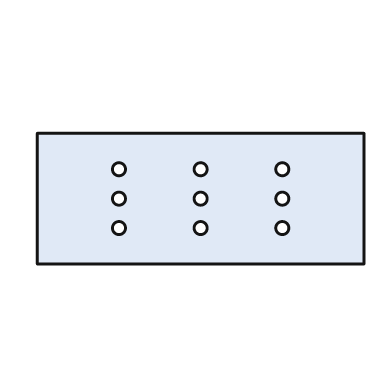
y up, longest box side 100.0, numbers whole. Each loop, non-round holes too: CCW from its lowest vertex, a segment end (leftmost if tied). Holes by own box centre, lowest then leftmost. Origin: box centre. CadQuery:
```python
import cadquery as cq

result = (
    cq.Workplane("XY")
    .moveTo(-50.0, -20.0)
    .lineTo(50.0, -20.0)
    .lineTo(50.0, 20.0)
    .lineTo(-50.0, 20.0)
    .close()
    .moveTo(-25.0, -9.0)
    .circle(2.0)
    .moveTo(0.0, -9.0)
    .circle(2.0)
    .moveTo(25.0, -9.0)
    .circle(2.0)
    .moveTo(-25.0, 0.0)
    .circle(2.0)
    .moveTo(0.0, 0.0)
    .circle(2.0)
    .moveTo(25.0, 0.0)
    .circle(2.0)
    .moveTo(-25.0, 9.0)
    .circle(2.0)
    .moveTo(0.0, 9.0)
    .circle(2.0)
    .moveTo(25.0, 9.0)
    .circle(2.0)
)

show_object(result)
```